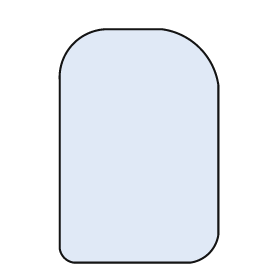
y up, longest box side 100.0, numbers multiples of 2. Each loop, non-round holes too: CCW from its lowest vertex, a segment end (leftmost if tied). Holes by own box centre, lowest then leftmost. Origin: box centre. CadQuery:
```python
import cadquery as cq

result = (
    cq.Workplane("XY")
    .moveTo(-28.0, -50.0)
    .lineTo(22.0, -50.0)
    .threePointArc((30.0, -46.0), (34.0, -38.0))
    .lineTo(34.0, 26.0)
    .threePointArc((26.0, 42.0), (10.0, 50.0))
    .lineTo(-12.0, 50.0)
    .threePointArc((-28.0, 44.0), (-34.0, 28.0))
    .lineTo(-34.0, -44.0)
    .threePointArc((-32.0, -48.0), (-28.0, -50.0))
    .close()
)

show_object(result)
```